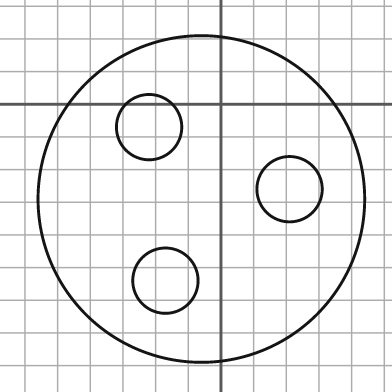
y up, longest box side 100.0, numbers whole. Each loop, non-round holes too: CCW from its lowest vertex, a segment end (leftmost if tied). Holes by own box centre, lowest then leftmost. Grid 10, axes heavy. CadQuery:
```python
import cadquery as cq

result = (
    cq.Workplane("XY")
    .moveTo(-6.0, -29.0)
    .circle(50.0)
    .moveTo(-17.0, -54.0)
    .circle(10.0)
    .moveTo(21.0, -26.0)
    .circle(10.0)
    .moveTo(-22.0, -7.0)
    .circle(10.0)
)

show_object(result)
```